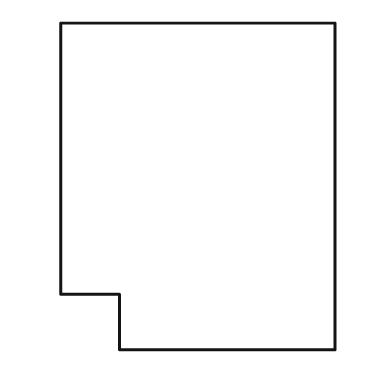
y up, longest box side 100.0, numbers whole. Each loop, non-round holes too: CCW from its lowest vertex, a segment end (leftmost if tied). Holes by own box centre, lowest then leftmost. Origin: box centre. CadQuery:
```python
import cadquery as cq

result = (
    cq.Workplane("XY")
    .moveTo(-24.0, -50.0)
    .lineTo(42.0, -50.0)
    .lineTo(42.0, 50.0)
    .lineTo(-42.0, 50.0)
    .lineTo(-42.0, -33.0)
    .lineTo(-24.0, -33.0)
    .close()
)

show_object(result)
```